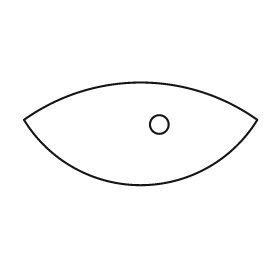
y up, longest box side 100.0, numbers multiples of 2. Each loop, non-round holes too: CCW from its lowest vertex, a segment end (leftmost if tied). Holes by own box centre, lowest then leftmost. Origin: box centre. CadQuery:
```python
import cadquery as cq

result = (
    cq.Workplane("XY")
    .moveTo(-50.0, 6.0)
    .threePointArc((0.0, -22.0), (50.0, 6.0))
    .threePointArc((0.0, 22.0), (-50.0, 6.0))
    .close()
    .moveTo(8.0, 4.0)
    .circle(4.0)
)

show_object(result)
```